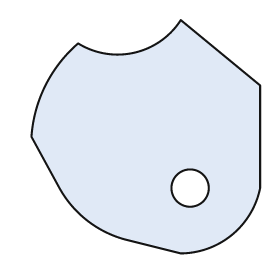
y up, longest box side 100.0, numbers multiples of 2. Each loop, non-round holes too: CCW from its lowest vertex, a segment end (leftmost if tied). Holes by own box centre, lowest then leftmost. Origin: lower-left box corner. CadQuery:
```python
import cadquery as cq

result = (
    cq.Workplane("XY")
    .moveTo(64.0, 0.0)
    .threePointArc((86.0, 8.0), (98.0, 28.0))
    .lineTo(98.0, 72.0)
    .lineTo(64.0, 100.0)
    .threePointArc((44.0, 86.0), (20.0, 90.0))
    .threePointArc((6.0, 72.0), (0.0, 50.0))
    .lineTo(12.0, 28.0)
    .threePointArc((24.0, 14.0), (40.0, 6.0))
    .close()
    .moveTo(68.0, 28.0)
    .circle(8.0)
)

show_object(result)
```